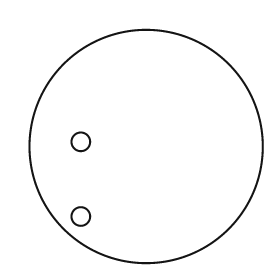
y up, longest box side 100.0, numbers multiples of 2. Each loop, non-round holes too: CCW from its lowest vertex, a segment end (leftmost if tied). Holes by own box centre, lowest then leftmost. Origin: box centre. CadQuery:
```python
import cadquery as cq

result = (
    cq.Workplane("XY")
    .moveTo(0.0, 0.0)
    .circle(50.0)
    .moveTo(-28.0, -30.0)
    .circle(4.0)
    .moveTo(-28.0, 2.0)
    .circle(4.0)
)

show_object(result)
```